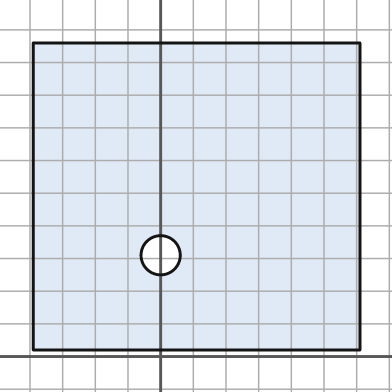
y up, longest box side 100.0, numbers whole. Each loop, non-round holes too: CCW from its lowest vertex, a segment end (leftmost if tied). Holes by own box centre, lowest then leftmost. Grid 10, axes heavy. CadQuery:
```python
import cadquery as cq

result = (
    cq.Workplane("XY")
    .moveTo(-39.0, 2.0)
    .lineTo(61.0, 2.0)
    .lineTo(61.0, 96.0)
    .lineTo(-39.0, 96.0)
    .close()
    .moveTo(0.0, 31.0)
    .circle(6.0)
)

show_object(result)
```